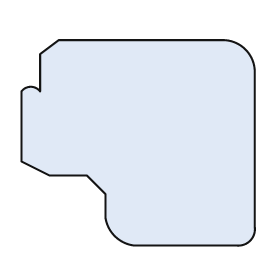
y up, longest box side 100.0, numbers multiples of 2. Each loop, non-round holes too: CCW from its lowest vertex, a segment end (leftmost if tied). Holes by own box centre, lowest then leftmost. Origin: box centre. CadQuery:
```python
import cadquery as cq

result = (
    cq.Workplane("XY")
    .moveTo(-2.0, -44.0)
    .lineTo(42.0, -44.0)
    .threePointArc((48.0, -42.0), (50.0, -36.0))
    .lineTo(50.0, 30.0)
    .threePointArc((46.0, 40.0), (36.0, 44.0))
    .lineTo(-34.0, 44.0)
    .lineTo(-42.0, 38.0)
    .lineTo(-42.0, 22.0)
    .threePointArc((-46.0, 24.0), (-50.0, 22.0))
    .lineTo(-50.0, -8.0)
    .lineTo(-38.0, -14.0)
    .lineTo(-22.0, -14.0)
    .lineTo(-14.0, -22.0)
    .lineTo(-14.0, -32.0)
    .threePointArc((-10.0, -40.0), (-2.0, -44.0))
    .close()
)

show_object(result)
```